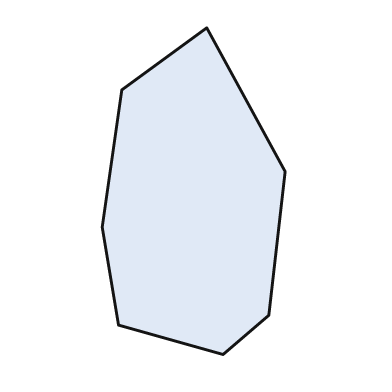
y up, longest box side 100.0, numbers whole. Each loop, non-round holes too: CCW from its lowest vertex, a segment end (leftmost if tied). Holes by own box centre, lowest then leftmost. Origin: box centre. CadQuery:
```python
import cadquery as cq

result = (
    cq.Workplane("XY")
    .moveTo(9.0, -50.0)
    .lineTo(23.0, -38.0)
    .lineTo(28.0, 6.0)
    .lineTo(4.0, 50.0)
    .lineTo(-22.0, 31.0)
    .lineTo(-28.0, -11.0)
    .lineTo(-23.0, -41.0)
    .close()
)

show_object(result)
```